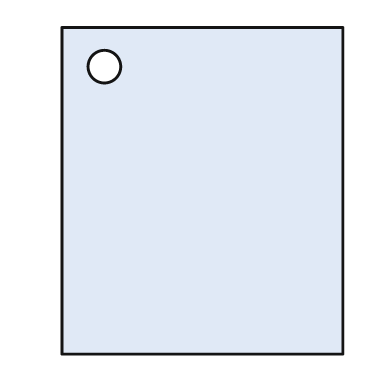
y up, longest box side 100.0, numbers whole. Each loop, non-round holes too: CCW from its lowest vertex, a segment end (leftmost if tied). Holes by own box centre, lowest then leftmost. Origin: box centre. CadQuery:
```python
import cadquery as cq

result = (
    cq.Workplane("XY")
    .moveTo(-43.0, -50.0)
    .lineTo(43.0, -50.0)
    .lineTo(43.0, 50.0)
    .lineTo(-43.0, 50.0)
    .close()
    .moveTo(-30.0, 38.0)
    .circle(5.0)
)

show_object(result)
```